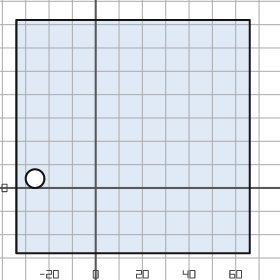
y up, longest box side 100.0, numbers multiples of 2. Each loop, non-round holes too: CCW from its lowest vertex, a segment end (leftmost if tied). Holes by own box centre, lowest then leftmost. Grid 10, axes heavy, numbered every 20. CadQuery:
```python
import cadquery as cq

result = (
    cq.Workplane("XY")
    .moveTo(-34.0, -28.0)
    .lineTo(66.0, -28.0)
    .lineTo(66.0, 72.0)
    .lineTo(-34.0, 72.0)
    .close()
    .moveTo(-26.0, 4.0)
    .circle(4.0)
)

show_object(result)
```